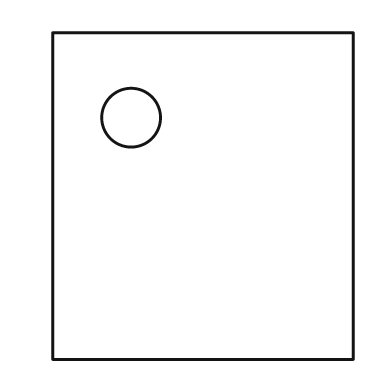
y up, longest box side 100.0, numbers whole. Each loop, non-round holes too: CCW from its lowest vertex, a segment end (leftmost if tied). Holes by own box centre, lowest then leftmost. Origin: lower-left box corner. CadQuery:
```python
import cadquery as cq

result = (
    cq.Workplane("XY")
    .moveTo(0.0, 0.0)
    .lineTo(92.0, 0.0)
    .lineTo(92.0, 100.0)
    .lineTo(0.0, 100.0)
    .close()
    .moveTo(24.0, 74.0)
    .circle(9.0)
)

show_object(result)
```